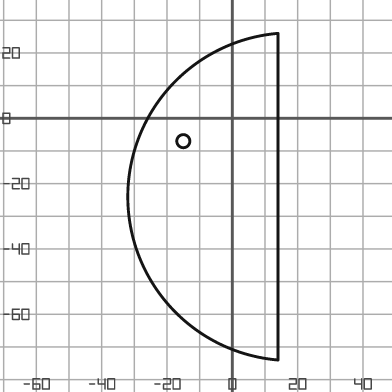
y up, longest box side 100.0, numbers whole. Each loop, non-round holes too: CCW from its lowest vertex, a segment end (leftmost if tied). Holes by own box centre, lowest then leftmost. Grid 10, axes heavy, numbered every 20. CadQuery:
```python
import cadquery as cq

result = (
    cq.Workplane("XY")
    .moveTo(14.0, -74.0)
    .lineTo(14.0, 26.0)
    .threePointArc((-32.0, -24.0), (14.0, -74.0))
    .close()
    .moveTo(-15.0, -7.0)
    .circle(2.0)
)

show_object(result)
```